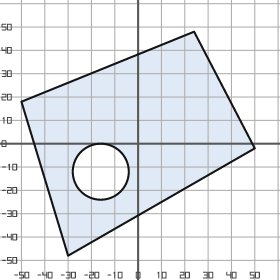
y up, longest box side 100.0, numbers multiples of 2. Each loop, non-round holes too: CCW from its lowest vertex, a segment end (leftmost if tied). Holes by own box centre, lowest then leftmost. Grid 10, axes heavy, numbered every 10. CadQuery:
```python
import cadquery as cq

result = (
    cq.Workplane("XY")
    .moveTo(-30.0, -48.0)
    .lineTo(50.0, -2.0)
    .lineTo(24.0, 48.0)
    .lineTo(-50.0, 18.0)
    .close()
    .moveTo(-16.0, -12.0)
    .circle(12.0)
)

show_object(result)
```